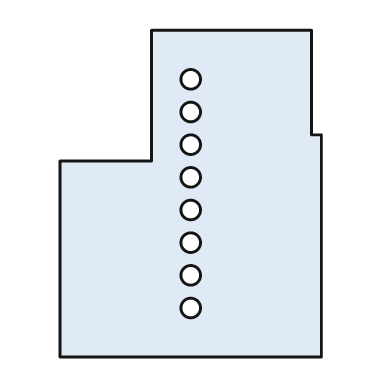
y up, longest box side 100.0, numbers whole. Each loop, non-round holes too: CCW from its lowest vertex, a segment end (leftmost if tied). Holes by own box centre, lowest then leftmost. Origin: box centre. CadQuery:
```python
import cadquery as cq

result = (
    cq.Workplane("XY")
    .moveTo(-40.0, -50.0)
    .lineTo(40.0, -50.0)
    .lineTo(40.0, 18.0)
    .lineTo(37.0, 18.0)
    .lineTo(37.0, 50.0)
    .lineTo(-12.0, 50.0)
    .lineTo(-12.0, 10.0)
    .lineTo(-40.0, 10.0)
    .close()
    .moveTo(0.0, -35.0)
    .circle(3.0)
    .moveTo(0.0, -25.0)
    .circle(3.0)
    .moveTo(0.0, -15.0)
    .circle(3.0)
    .moveTo(0.0, -5.0)
    .circle(3.0)
    .moveTo(0.0, 5.0)
    .circle(3.0)
    .moveTo(0.0, 15.0)
    .circle(3.0)
    .moveTo(0.0, 25.0)
    .circle(3.0)
    .moveTo(0.0, 35.0)
    .circle(3.0)
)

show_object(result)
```